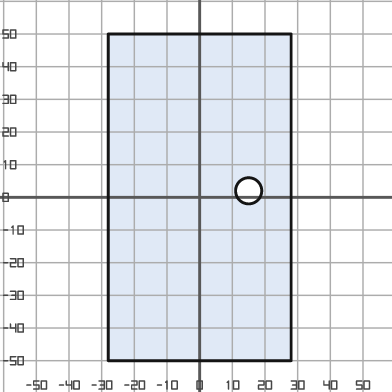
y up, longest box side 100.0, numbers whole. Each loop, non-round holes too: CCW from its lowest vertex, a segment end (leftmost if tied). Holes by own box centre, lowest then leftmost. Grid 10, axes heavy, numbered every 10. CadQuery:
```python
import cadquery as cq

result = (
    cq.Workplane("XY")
    .moveTo(-28.0, -50.0)
    .lineTo(28.0, -50.0)
    .lineTo(28.0, 50.0)
    .lineTo(-28.0, 50.0)
    .close()
    .moveTo(15.0, 2.0)
    .circle(4.0)
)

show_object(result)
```